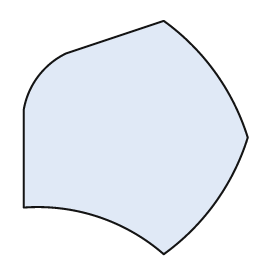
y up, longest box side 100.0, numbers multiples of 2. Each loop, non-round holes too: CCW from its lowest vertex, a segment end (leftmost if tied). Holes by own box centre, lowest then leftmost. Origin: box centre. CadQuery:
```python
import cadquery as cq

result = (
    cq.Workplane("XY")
    .moveTo(12.0, -50.0)
    .threePointArc((34.0, -28.0), (48.0, 0.0))
    .threePointArc((34.0, 28.0), (12.0, 50.0))
    .lineTo(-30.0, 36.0)
    .threePointArc((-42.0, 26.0), (-48.0, 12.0))
    .lineTo(-48.0, -30.0)
    .threePointArc((-16.0, -34.0), (12.0, -50.0))
    .close()
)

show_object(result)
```